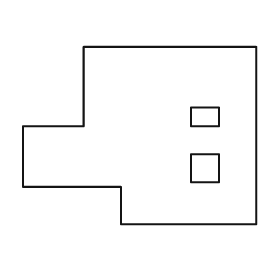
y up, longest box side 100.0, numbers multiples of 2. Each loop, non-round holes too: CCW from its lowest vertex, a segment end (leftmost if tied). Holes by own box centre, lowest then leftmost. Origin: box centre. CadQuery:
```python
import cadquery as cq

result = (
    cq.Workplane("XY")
    .moveTo(-8.0, -38.0)
    .lineTo(50.0, -38.0)
    .lineTo(50.0, 38.0)
    .lineTo(-24.0, 38.0)
    .lineTo(-24.0, 4.0)
    .lineTo(-50.0, 4.0)
    .lineTo(-50.0, -22.0)
    .lineTo(-8.0, -22.0)
    .close()
    .moveTo(22.0, -20.0)
    .lineTo(34.0, -20.0)
    .lineTo(34.0, -8.0)
    .lineTo(22.0, -8.0)
    .close()
    .moveTo(22.0, 4.0)
    .lineTo(34.0, 4.0)
    .lineTo(34.0, 12.0)
    .lineTo(22.0, 12.0)
    .close()
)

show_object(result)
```